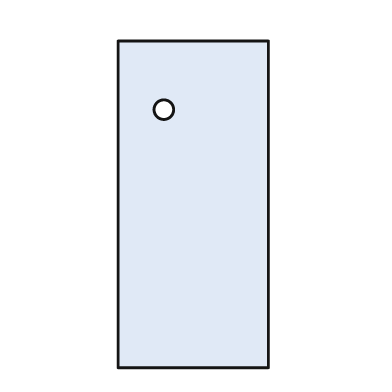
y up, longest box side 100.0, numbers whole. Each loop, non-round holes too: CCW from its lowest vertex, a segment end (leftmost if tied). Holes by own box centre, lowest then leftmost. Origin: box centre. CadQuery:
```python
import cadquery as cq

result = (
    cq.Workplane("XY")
    .moveTo(-23.0, -50.0)
    .lineTo(23.0, -50.0)
    .lineTo(23.0, 50.0)
    .lineTo(-23.0, 50.0)
    .close()
    .moveTo(-9.0, 29.0)
    .circle(3.0)
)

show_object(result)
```